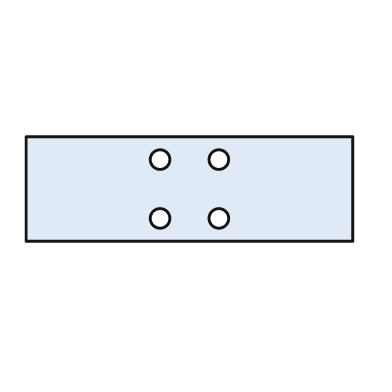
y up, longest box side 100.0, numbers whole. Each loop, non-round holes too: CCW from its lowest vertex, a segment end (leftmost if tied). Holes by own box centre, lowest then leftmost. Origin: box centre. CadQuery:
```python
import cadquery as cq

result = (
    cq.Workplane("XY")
    .moveTo(-50.0, -16.0)
    .lineTo(50.0, -16.0)
    .lineTo(50.0, 16.0)
    .lineTo(-50.0, 16.0)
    .close()
    .moveTo(-9.0, -9.0)
    .circle(3.0)
    .moveTo(9.0, -9.0)
    .circle(3.0)
    .moveTo(-9.0, 9.0)
    .circle(3.0)
    .moveTo(9.0, 9.0)
    .circle(3.0)
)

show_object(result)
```